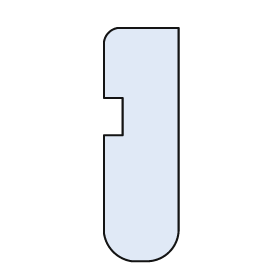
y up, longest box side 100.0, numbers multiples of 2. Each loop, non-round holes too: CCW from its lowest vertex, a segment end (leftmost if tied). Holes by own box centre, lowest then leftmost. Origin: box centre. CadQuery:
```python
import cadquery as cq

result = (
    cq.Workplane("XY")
    .moveTo(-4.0, -50.0)
    .lineTo(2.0, -50.0)
    .threePointArc((12.0, -46.0), (16.0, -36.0))
    .lineTo(16.0, 50.0)
    .lineTo(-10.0, 50.0)
    .threePointArc((-14.0, 48.0), (-16.0, 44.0))
    .lineTo(-16.0, 20.0)
    .lineTo(-8.0, 20.0)
    .lineTo(-8.0, 4.0)
    .lineTo(-16.0, 4.0)
    .lineTo(-16.0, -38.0)
    .threePointArc((-12.0, -46.0), (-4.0, -50.0))
    .close()
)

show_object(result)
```